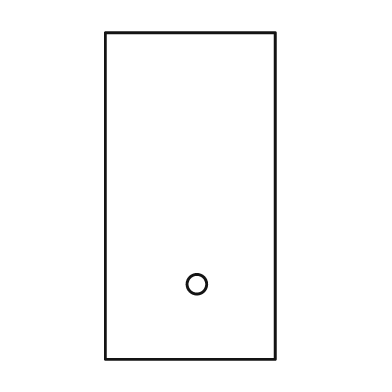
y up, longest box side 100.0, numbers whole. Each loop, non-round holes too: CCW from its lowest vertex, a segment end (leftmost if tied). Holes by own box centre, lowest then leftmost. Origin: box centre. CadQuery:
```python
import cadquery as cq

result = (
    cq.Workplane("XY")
    .moveTo(-26.0, -50.0)
    .lineTo(26.0, -50.0)
    .lineTo(26.0, 50.0)
    .lineTo(-26.0, 50.0)
    .close()
    .moveTo(2.0, -27.0)
    .circle(3.0)
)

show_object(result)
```